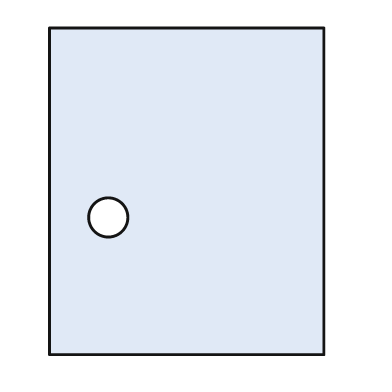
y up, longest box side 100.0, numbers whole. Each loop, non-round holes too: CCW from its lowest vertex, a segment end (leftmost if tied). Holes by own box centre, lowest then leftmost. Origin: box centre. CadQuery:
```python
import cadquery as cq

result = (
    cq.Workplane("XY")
    .moveTo(-42.0, -50.0)
    .lineTo(42.0, -50.0)
    .lineTo(42.0, 50.0)
    .lineTo(-42.0, 50.0)
    .close()
    .moveTo(-24.0, -8.0)
    .circle(6.0)
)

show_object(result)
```